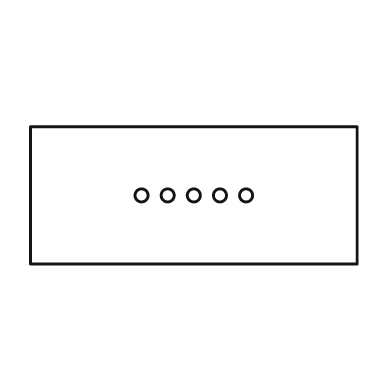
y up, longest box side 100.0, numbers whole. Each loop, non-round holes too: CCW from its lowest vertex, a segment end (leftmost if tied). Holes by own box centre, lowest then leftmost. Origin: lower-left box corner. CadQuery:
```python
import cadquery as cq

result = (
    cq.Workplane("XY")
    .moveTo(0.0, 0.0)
    .lineTo(100.0, 0.0)
    .lineTo(100.0, 42.0)
    .lineTo(0.0, 42.0)
    .close()
    .moveTo(34.0, 21.0)
    .circle(2.0)
    .moveTo(42.0, 21.0)
    .circle(2.0)
    .moveTo(50.0, 21.0)
    .circle(2.0)
    .moveTo(58.0, 21.0)
    .circle(2.0)
    .moveTo(66.0, 21.0)
    .circle(2.0)
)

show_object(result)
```